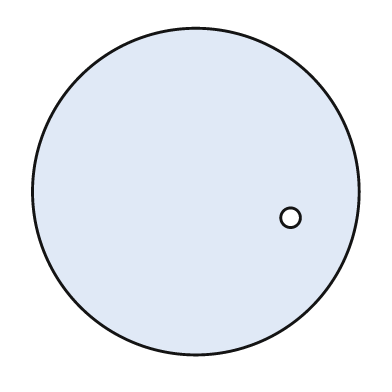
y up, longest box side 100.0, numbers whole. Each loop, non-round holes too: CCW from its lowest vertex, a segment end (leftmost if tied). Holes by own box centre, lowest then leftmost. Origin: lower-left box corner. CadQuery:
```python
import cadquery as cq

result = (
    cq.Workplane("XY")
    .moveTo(50.0, 50.0)
    .circle(50.0)
    .moveTo(79.0, 42.0)
    .circle(3.0)
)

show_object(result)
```